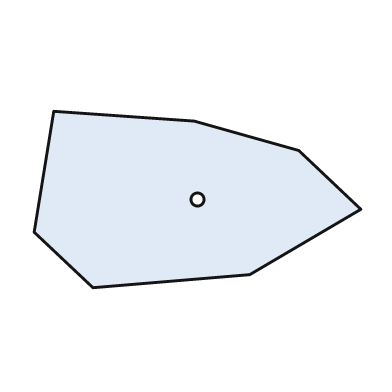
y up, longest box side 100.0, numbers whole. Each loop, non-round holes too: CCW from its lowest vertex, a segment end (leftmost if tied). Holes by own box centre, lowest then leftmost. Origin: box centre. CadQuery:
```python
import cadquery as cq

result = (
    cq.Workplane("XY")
    .moveTo(-32.0, -27.0)
    .lineTo(16.0, -23.0)
    .lineTo(50.0, -3.0)
    .lineTo(31.0, 15.0)
    .lineTo(-1.0, 24.0)
    .lineTo(-44.0, 27.0)
    .lineTo(-50.0, -10.0)
    .close()
    .moveTo(0.0, 0.0)
    .circle(2.0)
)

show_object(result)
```